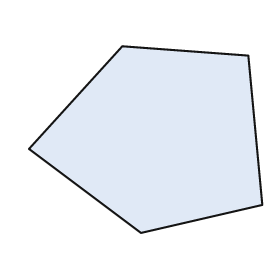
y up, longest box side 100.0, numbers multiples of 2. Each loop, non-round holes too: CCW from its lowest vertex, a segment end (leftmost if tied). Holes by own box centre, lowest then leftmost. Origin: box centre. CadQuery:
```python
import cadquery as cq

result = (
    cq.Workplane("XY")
    .moveTo(-2.0, -40.0)
    .lineTo(50.0, -28.0)
    .lineTo(44.0, 36.0)
    .lineTo(-10.0, 40.0)
    .lineTo(-50.0, -4.0)
    .close()
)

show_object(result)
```